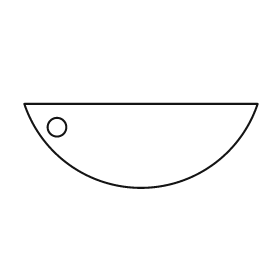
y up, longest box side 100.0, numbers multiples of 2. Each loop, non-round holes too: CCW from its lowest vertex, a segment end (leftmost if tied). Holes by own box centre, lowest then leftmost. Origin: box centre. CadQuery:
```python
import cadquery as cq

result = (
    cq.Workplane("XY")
    .moveTo(-50.0, 18.0)
    .threePointArc((0.0, -18.0), (50.0, 18.0))
    .close()
    .moveTo(-36.0, 8.0)
    .circle(4.0)
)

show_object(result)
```